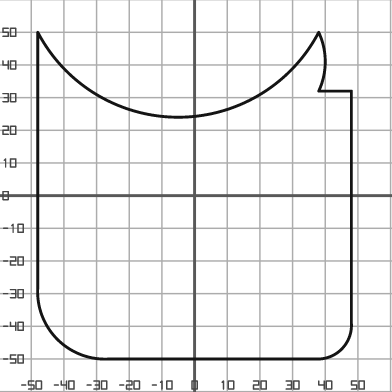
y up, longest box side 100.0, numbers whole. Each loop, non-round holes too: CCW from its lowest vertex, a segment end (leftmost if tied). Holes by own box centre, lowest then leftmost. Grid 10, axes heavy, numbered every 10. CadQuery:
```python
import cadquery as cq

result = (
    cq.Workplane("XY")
    .moveTo(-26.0, -50.0)
    .lineTo(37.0, -50.0)
    .threePointArc((45.0, -47.0), (48.0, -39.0))
    .lineTo(48.0, 32.0)
    .lineTo(38.0, 32.0)
    .threePointArc((40.0, 41.0), (38.0, 50.0))
    .threePointArc((-5.0, 24.0), (-48.0, 50.0))
    .lineTo(-48.0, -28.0)
    .threePointArc((-42.0, -44.0), (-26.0, -50.0))
    .close()
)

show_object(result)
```